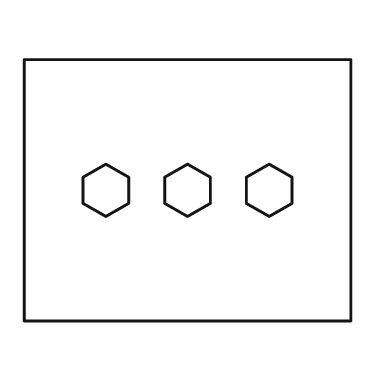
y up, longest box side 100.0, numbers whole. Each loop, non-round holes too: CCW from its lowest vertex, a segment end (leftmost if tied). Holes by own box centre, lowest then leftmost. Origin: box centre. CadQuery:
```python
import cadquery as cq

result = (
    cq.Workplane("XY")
    .moveTo(-50.0, -40.0)
    .lineTo(50.0, -40.0)
    .lineTo(50.0, 40.0)
    .lineTo(-50.0, 40.0)
    .close()
    .moveTo(-25.0, -8.0)
    .lineTo(-18.0, -4.0)
    .lineTo(-18.0, 4.0)
    .lineTo(-25.0, 8.0)
    .lineTo(-32.0, 4.0)
    .lineTo(-32.0, -4.0)
    .close()
    .moveTo(0.0, -8.0)
    .lineTo(7.0, -4.0)
    .lineTo(7.0, 4.0)
    .lineTo(0.0, 8.0)
    .lineTo(-7.0, 4.0)
    .lineTo(-7.0, -4.0)
    .close()
    .moveTo(25.0, -8.0)
    .lineTo(32.0, -4.0)
    .lineTo(32.0, 4.0)
    .lineTo(25.0, 8.0)
    .lineTo(18.0, 4.0)
    .lineTo(18.0, -4.0)
    .close()
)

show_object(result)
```